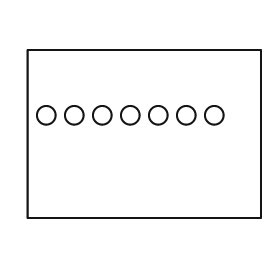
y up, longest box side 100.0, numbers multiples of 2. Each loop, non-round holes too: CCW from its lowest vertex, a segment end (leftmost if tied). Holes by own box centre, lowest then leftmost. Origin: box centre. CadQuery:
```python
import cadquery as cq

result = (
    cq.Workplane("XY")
    .moveTo(-50.0, -36.0)
    .lineTo(50.0, -36.0)
    .lineTo(50.0, 36.0)
    .lineTo(-50.0, 36.0)
    .close()
    .moveTo(-42.0, 8.0)
    .circle(4.0)
    .moveTo(-30.0, 8.0)
    .circle(4.0)
    .moveTo(-18.0, 8.0)
    .circle(4.0)
    .moveTo(-6.0, 8.0)
    .circle(4.0)
    .moveTo(6.0, 8.0)
    .circle(4.0)
    .moveTo(18.0, 8.0)
    .circle(4.0)
    .moveTo(30.0, 8.0)
    .circle(4.0)
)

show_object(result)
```